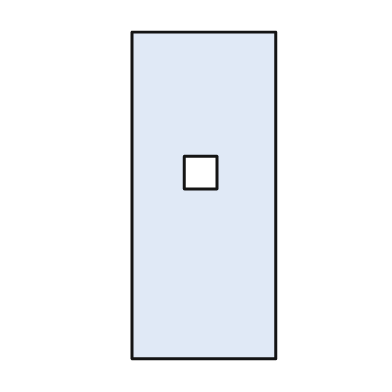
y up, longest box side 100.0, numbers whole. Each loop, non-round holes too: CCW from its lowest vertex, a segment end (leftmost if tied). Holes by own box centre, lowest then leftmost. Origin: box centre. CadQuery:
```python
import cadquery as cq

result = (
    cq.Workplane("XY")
    .moveTo(-22.0, -50.0)
    .lineTo(22.0, -50.0)
    .lineTo(22.0, 50.0)
    .lineTo(-22.0, 50.0)
    .close()
    .moveTo(-6.0, 2.0)
    .lineTo(4.0, 2.0)
    .lineTo(4.0, 12.0)
    .lineTo(-6.0, 12.0)
    .close()
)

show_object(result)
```